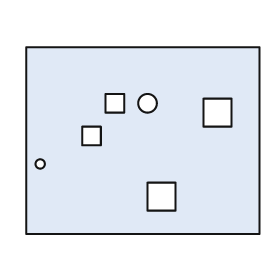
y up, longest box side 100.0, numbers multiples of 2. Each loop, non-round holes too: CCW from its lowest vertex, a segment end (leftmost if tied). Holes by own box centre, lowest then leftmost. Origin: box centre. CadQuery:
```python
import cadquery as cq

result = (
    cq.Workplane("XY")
    .moveTo(-50.0, -40.0)
    .lineTo(50.0, -40.0)
    .lineTo(50.0, 40.0)
    .lineTo(-50.0, 40.0)
    .close()
    .moveTo(2.0, -30.0)
    .lineTo(14.0, -30.0)
    .lineTo(14.0, -18.0)
    .lineTo(2.0, -18.0)
    .close()
    .moveTo(-44.0, -10.0)
    .circle(2.0)
    .moveTo(-26.0, -2.0)
    .lineTo(-18.0, -2.0)
    .lineTo(-18.0, 6.0)
    .lineTo(-26.0, 6.0)
    .close()
    .moveTo(26.0, 6.0)
    .lineTo(38.0, 6.0)
    .lineTo(38.0, 18.0)
    .lineTo(26.0, 18.0)
    .close()
    .moveTo(-16.0, 12.0)
    .lineTo(-8.0, 12.0)
    .lineTo(-8.0, 20.0)
    .lineTo(-16.0, 20.0)
    .close()
    .moveTo(2.0, 16.0)
    .circle(4.0)
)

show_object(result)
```